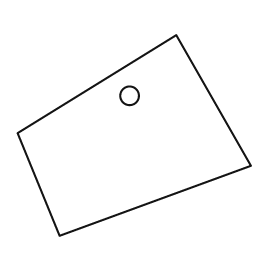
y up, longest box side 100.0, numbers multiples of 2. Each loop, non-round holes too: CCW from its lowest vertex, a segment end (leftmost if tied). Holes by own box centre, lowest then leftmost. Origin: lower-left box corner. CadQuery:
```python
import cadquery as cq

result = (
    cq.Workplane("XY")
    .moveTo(18.0, 0.0)
    .lineTo(100.0, 30.0)
    .lineTo(68.0, 86.0)
    .lineTo(0.0, 44.0)
    .close()
    .moveTo(48.0, 60.0)
    .circle(4.0)
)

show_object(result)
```